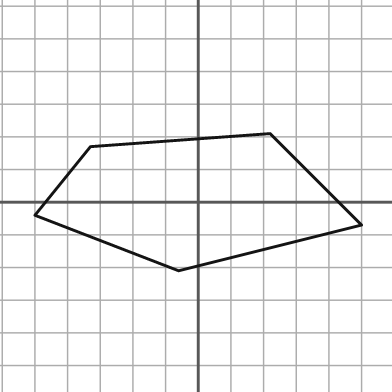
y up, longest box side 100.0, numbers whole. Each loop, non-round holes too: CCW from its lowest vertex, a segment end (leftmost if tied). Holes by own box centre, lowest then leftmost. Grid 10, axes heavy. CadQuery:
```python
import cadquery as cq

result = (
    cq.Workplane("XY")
    .moveTo(-6.0, -21.0)
    .lineTo(50.0, -7.0)
    .lineTo(22.0, 21.0)
    .lineTo(-33.0, 17.0)
    .lineTo(-50.0, -4.0)
    .close()
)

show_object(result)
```